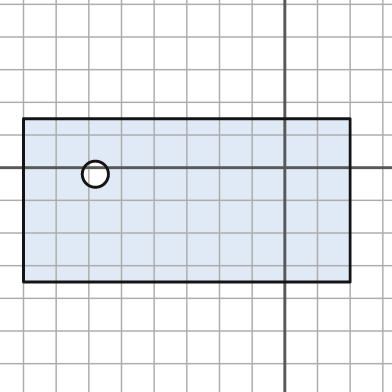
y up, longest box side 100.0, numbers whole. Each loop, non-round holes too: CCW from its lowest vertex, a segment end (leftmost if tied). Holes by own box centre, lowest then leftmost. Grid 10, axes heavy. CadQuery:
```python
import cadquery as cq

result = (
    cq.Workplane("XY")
    .moveTo(-80.0, -35.0)
    .lineTo(20.0, -35.0)
    .lineTo(20.0, 15.0)
    .lineTo(-80.0, 15.0)
    .close()
    .moveTo(-58.0, -2.0)
    .circle(4.0)
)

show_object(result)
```